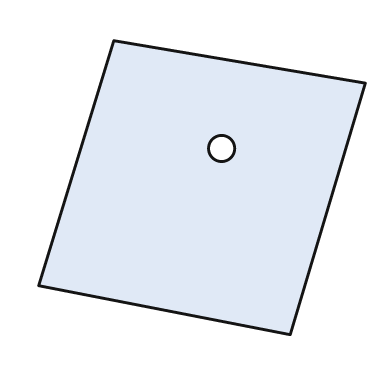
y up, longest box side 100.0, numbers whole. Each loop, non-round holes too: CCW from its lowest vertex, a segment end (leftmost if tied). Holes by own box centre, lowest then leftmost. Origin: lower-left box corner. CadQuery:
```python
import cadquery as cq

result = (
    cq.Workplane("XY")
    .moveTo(77.0, 0.0)
    .lineTo(100.0, 77.0)
    .lineTo(23.0, 90.0)
    .lineTo(0.0, 15.0)
    .close()
    .moveTo(56.0, 57.0)
    .circle(4.0)
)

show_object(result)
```